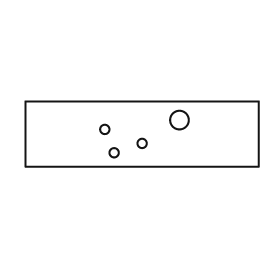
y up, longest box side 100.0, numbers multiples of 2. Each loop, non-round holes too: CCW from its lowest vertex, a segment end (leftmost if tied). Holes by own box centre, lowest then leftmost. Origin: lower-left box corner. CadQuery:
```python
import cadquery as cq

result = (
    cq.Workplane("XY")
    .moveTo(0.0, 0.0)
    .lineTo(100.0, 0.0)
    .lineTo(100.0, 28.0)
    .lineTo(0.0, 28.0)
    .close()
    .moveTo(38.0, 6.0)
    .circle(2.0)
    .moveTo(50.0, 10.0)
    .circle(2.0)
    .moveTo(34.0, 16.0)
    .circle(2.0)
    .moveTo(66.0, 20.0)
    .circle(4.0)
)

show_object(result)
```